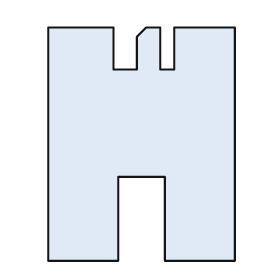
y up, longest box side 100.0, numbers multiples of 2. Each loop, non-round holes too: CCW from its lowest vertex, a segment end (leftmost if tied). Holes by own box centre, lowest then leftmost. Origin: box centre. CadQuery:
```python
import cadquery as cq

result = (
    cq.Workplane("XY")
    .moveTo(-40.0, -50.0)
    .lineTo(-10.0, -50.0)
    .lineTo(-10.0, -14.0)
    .lineTo(10.0, -14.0)
    .lineTo(10.0, -50.0)
    .lineTo(40.0, -50.0)
    .lineTo(40.0, 50.0)
    .lineTo(14.0, 50.0)
    .lineTo(14.0, 32.0)
    .lineTo(8.0, 32.0)
    .lineTo(8.0, 50.0)
    .lineTo(2.0, 50.0)
    .lineTo(-2.0, 46.0)
    .lineTo(-2.0, 32.0)
    .lineTo(-12.0, 32.0)
    .lineTo(-12.0, 50.0)
    .lineTo(-40.0, 50.0)
    .close()
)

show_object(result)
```